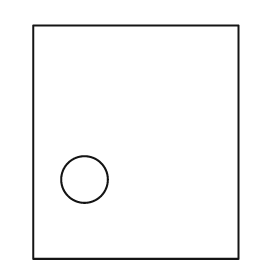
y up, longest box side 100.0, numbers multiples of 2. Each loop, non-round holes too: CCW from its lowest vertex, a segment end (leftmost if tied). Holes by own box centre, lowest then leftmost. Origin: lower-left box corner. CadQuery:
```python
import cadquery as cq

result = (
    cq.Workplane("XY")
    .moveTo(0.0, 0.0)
    .lineTo(88.0, 0.0)
    .lineTo(88.0, 100.0)
    .lineTo(0.0, 100.0)
    .close()
    .moveTo(22.0, 34.0)
    .circle(10.0)
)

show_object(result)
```